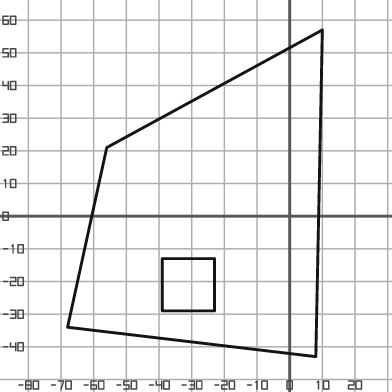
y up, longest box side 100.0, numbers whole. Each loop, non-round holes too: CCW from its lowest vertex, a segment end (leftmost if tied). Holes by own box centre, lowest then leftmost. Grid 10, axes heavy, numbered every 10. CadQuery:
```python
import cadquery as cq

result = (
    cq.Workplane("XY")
    .moveTo(8.0, -43.0)
    .lineTo(10.0, 57.0)
    .lineTo(-56.0, 21.0)
    .lineTo(-68.0, -34.0)
    .close()
    .moveTo(-39.0, -29.0)
    .lineTo(-23.0, -29.0)
    .lineTo(-23.0, -13.0)
    .lineTo(-39.0, -13.0)
    .close()
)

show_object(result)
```